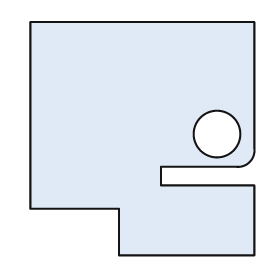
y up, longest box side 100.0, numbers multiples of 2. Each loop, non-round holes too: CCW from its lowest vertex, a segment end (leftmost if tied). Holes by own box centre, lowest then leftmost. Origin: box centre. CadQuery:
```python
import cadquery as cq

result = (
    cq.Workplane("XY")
    .moveTo(-10.0, -50.0)
    .lineTo(48.0, -50.0)
    .lineTo(48.0, -20.0)
    .lineTo(8.0, -20.0)
    .lineTo(8.0, -12.0)
    .lineTo(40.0, -12.0)
    .threePointArc((46.0, -10.0), (48.0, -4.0))
    .lineTo(48.0, 50.0)
    .lineTo(-48.0, 50.0)
    .lineTo(-48.0, -30.0)
    .lineTo(-10.0, -30.0)
    .close()
    .moveTo(32.0, 2.0)
    .circle(10.0)
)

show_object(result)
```